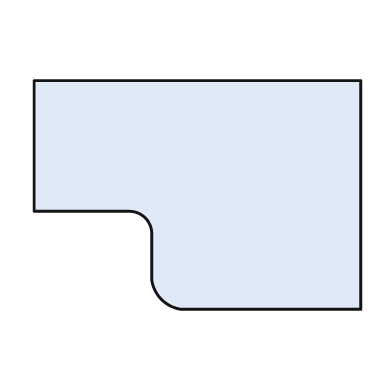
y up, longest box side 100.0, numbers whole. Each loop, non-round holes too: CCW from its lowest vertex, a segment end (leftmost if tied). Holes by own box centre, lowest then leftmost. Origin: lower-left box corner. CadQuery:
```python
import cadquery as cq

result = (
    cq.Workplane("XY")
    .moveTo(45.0, 0.0)
    .lineTo(100.0, 0.0)
    .lineTo(100.0, 70.0)
    .lineTo(0.0, 70.0)
    .lineTo(0.0, 30.0)
    .lineTo(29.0, 30.0)
    .threePointArc((34.0, 28.0), (36.0, 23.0))
    .lineTo(36.0, 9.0)
    .threePointArc((39.0, 3.0), (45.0, 0.0))
    .close()
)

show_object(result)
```